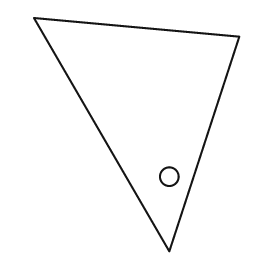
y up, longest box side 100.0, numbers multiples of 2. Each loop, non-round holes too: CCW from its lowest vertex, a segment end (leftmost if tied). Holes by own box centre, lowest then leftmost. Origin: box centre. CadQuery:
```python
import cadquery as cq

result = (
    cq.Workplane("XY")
    .moveTo(14.0, -50.0)
    .lineTo(44.0, 42.0)
    .lineTo(-44.0, 50.0)
    .close()
    .moveTo(14.0, -18.0)
    .circle(4.0)
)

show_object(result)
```